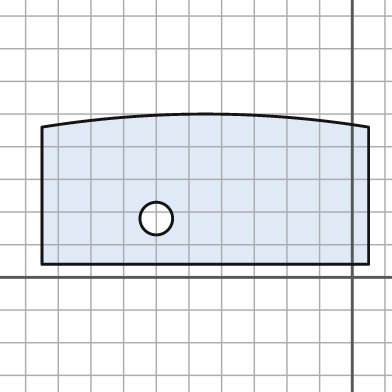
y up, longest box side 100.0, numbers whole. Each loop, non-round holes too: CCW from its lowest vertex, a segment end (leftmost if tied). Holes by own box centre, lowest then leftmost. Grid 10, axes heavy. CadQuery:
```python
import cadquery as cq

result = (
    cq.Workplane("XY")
    .moveTo(-95.0, 4.0)
    .lineTo(5.0, 4.0)
    .lineTo(5.0, 46.0)
    .threePointArc((-45.0, 50.0), (-95.0, 46.0))
    .close()
    .moveTo(-60.0, 18.0)
    .circle(5.0)
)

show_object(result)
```